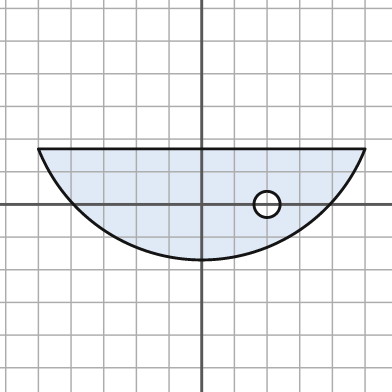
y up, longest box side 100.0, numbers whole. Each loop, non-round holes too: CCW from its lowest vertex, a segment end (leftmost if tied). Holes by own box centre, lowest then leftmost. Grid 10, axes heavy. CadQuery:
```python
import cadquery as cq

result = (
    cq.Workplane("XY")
    .moveTo(-50.0, 17.0)
    .threePointArc((0.0, -17.0), (50.0, 17.0))
    .close()
    .moveTo(20.0, 0.0)
    .circle(4.0)
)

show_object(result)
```